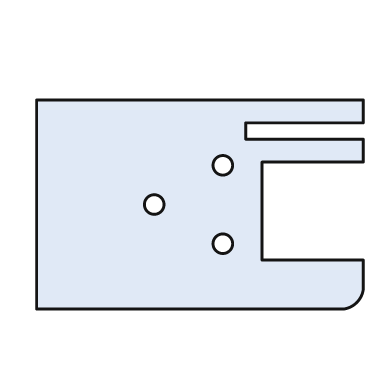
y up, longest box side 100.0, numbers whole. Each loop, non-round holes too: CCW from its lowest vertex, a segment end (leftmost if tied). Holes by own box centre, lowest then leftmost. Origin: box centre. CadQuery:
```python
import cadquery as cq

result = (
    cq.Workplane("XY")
    .moveTo(-50.0, -32.0)
    .lineTo(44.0, -32.0)
    .threePointArc((48.0, -30.0), (50.0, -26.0))
    .lineTo(50.0, -17.0)
    .lineTo(19.0, -17.0)
    .lineTo(19.0, 13.0)
    .lineTo(50.0, 13.0)
    .lineTo(50.0, 20.0)
    .lineTo(14.0, 20.0)
    .lineTo(14.0, 25.0)
    .lineTo(50.0, 25.0)
    .lineTo(50.0, 32.0)
    .lineTo(-50.0, 32.0)
    .close()
    .moveTo(7.0, -12.0)
    .circle(3.0)
    .moveTo(-14.0, 0.0)
    .circle(3.0)
    .moveTo(7.0, 12.0)
    .circle(3.0)
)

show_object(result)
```